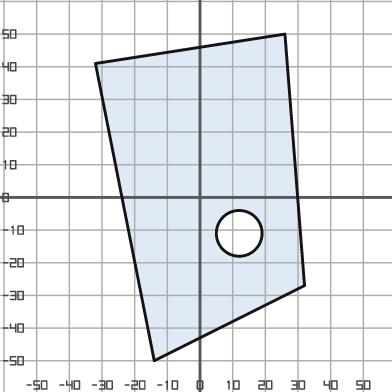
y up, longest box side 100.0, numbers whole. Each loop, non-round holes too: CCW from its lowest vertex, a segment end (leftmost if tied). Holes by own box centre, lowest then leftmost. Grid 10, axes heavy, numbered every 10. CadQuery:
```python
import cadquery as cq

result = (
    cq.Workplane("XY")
    .moveTo(-14.0, -50.0)
    .lineTo(32.0, -27.0)
    .lineTo(26.0, 50.0)
    .lineTo(-32.0, 41.0)
    .close()
    .moveTo(12.0, -11.0)
    .circle(7.0)
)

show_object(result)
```